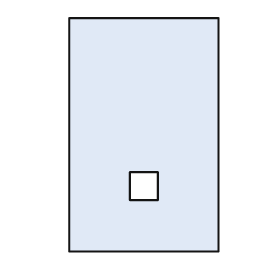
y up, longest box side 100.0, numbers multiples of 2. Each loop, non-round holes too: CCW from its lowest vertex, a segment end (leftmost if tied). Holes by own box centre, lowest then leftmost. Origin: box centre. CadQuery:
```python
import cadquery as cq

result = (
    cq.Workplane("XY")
    .moveTo(-32.0, -50.0)
    .lineTo(32.0, -50.0)
    .lineTo(32.0, 50.0)
    .lineTo(-32.0, 50.0)
    .close()
    .moveTo(-6.0, -28.0)
    .lineTo(6.0, -28.0)
    .lineTo(6.0, -16.0)
    .lineTo(-6.0, -16.0)
    .close()
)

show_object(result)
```